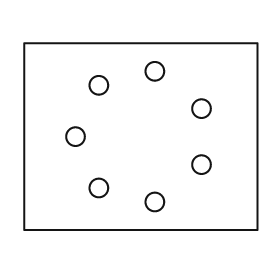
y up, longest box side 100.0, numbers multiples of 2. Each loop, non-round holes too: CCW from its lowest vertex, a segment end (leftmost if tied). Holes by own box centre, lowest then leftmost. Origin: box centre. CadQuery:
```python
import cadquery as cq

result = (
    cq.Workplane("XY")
    .moveTo(-50.0, -40.0)
    .lineTo(50.0, -40.0)
    .lineTo(50.0, 40.0)
    .lineTo(-50.0, 40.0)
    .close()
    .moveTo(6.0, -28.0)
    .circle(4.0)
    .moveTo(-18.0, -22.0)
    .circle(4.0)
    .moveTo(26.0, -12.0)
    .circle(4.0)
    .moveTo(-28.0, 0.0)
    .circle(4.0)
    .moveTo(26.0, 12.0)
    .circle(4.0)
    .moveTo(-18.0, 22.0)
    .circle(4.0)
    .moveTo(6.0, 28.0)
    .circle(4.0)
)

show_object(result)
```